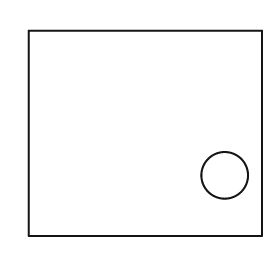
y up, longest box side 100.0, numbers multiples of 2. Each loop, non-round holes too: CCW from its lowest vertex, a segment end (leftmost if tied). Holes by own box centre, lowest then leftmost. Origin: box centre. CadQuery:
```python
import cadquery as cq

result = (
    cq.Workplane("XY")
    .moveTo(-50.0, -44.0)
    .lineTo(50.0, -44.0)
    .lineTo(50.0, 44.0)
    .lineTo(-50.0, 44.0)
    .close()
    .moveTo(34.0, -18.0)
    .circle(10.0)
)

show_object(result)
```